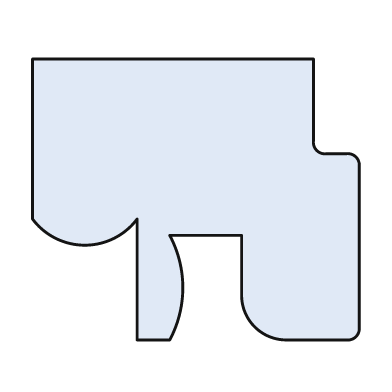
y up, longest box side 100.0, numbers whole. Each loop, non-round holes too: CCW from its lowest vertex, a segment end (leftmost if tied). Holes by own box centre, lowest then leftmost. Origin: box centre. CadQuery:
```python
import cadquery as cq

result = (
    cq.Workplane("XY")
    .moveTo(-18.0, -43.0)
    .lineTo(-8.0, -43.0)
    .threePointArc((-4.0, -27.0), (-8.0, -11.0))
    .lineTo(14.0, -11.0)
    .lineTo(14.0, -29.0)
    .threePointArc((18.0, -39.0), (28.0, -43.0))
    .lineTo(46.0, -43.0)
    .threePointArc((49.0, -42.0), (50.0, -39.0))
    .lineTo(50.0, 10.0)
    .threePointArc((49.0, 13.0), (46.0, 14.0))
    .lineTo(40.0, 14.0)
    .threePointArc((37.0, 15.0), (36.0, 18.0))
    .lineTo(36.0, 43.0)
    .lineTo(-50.0, 43.0)
    .lineTo(-50.0, -6.0)
    .threePointArc((-34.0, -14.0), (-18.0, -6.0))
    .close()
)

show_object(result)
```